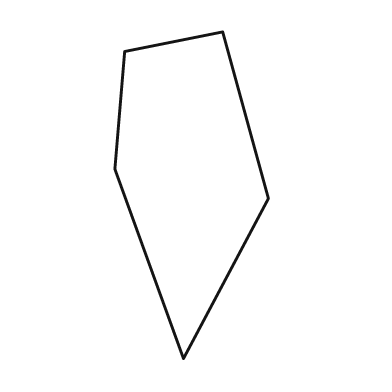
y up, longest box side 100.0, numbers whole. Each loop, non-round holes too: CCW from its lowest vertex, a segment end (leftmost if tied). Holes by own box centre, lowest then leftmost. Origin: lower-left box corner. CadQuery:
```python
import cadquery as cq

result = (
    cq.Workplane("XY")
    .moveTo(21.0, 0.0)
    .lineTo(47.0, 49.0)
    .lineTo(33.0, 100.0)
    .lineTo(3.0, 94.0)
    .lineTo(0.0, 58.0)
    .close()
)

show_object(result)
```